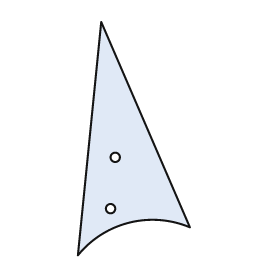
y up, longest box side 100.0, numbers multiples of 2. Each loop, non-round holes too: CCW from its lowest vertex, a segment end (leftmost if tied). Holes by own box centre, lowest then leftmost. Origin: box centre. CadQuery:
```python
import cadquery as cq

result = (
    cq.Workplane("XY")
    .moveTo(-24.0, -50.0)
    .threePointArc((-2.0, -36.0), (24.0, -38.0))
    .lineTo(-14.0, 50.0)
    .close()
    .moveTo(-10.0, -30.0)
    .circle(2.0)
    .moveTo(-8.0, -8.0)
    .circle(2.0)
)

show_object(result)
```